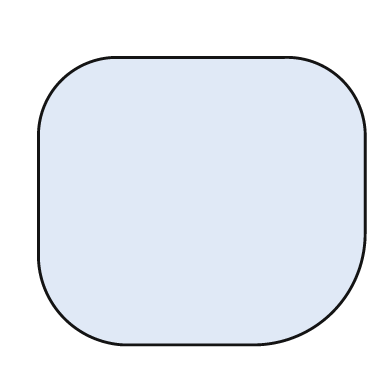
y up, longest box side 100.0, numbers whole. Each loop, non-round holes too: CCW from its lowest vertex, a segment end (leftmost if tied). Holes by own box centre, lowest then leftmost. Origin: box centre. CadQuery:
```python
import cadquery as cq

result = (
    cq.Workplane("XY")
    .moveTo(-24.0, -44.0)
    .lineTo(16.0, -44.0)
    .threePointArc((40.0, -34.0), (50.0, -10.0))
    .lineTo(50.0, 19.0)
    .threePointArc((43.0, 37.0), (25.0, 44.0))
    .lineTo(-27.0, 44.0)
    .threePointArc((-43.0, 37.0), (-50.0, 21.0))
    .lineTo(-50.0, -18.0)
    .threePointArc((-42.0, -36.0), (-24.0, -44.0))
    .close()
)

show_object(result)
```